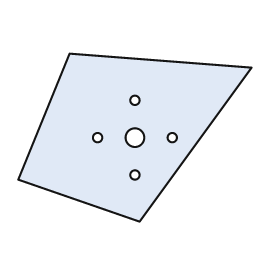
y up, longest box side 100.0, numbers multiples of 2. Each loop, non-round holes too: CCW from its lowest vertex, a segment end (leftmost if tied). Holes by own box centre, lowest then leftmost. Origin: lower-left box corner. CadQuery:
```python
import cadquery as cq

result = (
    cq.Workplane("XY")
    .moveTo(52.0, 0.0)
    .lineTo(100.0, 66.0)
    .lineTo(22.0, 72.0)
    .lineTo(0.0, 18.0)
    .close()
    .moveTo(50.0, 20.0)
    .circle(2.0)
    .moveTo(34.0, 36.0)
    .circle(2.0)
    .moveTo(50.0, 36.0)
    .circle(4.0)
    .moveTo(66.0, 36.0)
    .circle(2.0)
    .moveTo(50.0, 52.0)
    .circle(2.0)
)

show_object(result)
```